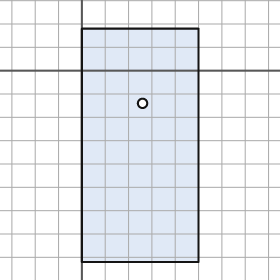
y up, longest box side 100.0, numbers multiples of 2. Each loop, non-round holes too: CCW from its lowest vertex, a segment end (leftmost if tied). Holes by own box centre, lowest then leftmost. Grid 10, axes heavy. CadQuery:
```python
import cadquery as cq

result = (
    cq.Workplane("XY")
    .moveTo(0.0, -82.0)
    .lineTo(50.0, -82.0)
    .lineTo(50.0, 18.0)
    .lineTo(0.0, 18.0)
    .close()
    .moveTo(26.0, -14.0)
    .circle(2.0)
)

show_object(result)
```